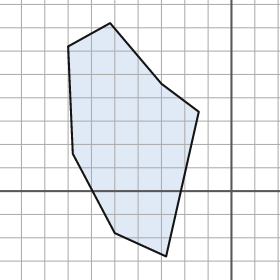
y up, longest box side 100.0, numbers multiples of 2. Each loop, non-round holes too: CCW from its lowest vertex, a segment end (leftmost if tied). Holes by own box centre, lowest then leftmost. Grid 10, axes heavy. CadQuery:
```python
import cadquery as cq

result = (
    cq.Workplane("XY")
    .moveTo(-28.0, -28.0)
    .lineTo(-14.0, 34.0)
    .lineTo(-30.0, 46.0)
    .lineTo(-52.0, 72.0)
    .lineTo(-70.0, 62.0)
    .lineTo(-68.0, 16.0)
    .lineTo(-50.0, -18.0)
    .close()
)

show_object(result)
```